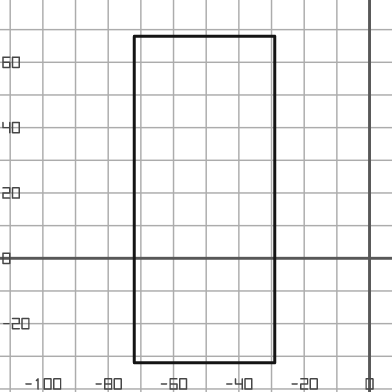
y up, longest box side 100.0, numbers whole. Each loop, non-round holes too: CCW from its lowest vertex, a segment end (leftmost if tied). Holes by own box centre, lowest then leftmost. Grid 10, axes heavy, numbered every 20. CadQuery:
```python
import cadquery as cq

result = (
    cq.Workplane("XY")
    .moveTo(-72.0, -32.0)
    .lineTo(-29.0, -32.0)
    .lineTo(-29.0, 68.0)
    .lineTo(-72.0, 68.0)
    .close()
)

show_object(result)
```